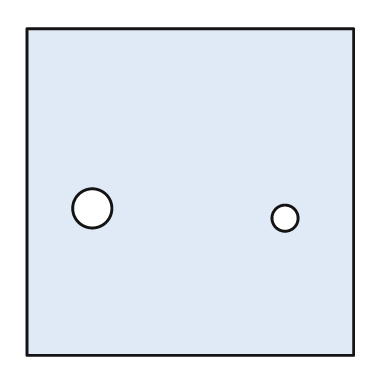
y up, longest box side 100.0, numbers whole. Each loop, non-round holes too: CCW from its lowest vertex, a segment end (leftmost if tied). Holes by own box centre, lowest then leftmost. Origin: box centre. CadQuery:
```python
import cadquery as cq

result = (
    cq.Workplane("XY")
    .moveTo(-50.0, -50.0)
    .lineTo(50.0, -50.0)
    .lineTo(50.0, 50.0)
    .lineTo(-50.0, 50.0)
    .close()
    .moveTo(29.0, -8.0)
    .circle(4.0)
    .moveTo(-30.0, -5.0)
    .circle(6.0)
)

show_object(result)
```